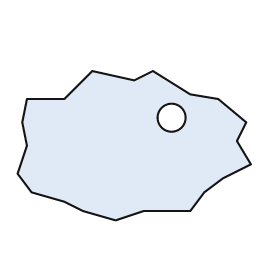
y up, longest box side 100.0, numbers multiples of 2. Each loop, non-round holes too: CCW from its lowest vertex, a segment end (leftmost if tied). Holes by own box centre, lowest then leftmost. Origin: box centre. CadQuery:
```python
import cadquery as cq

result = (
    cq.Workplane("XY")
    .moveTo(-8.0, -32.0)
    .lineTo(4.0, -28.0)
    .lineTo(24.0, -28.0)
    .lineTo(30.0, -20.0)
    .lineTo(38.0, -14.0)
    .lineTo(50.0, -8.0)
    .lineTo(44.0, 2.0)
    .lineTo(48.0, 10.0)
    .lineTo(36.0, 20.0)
    .lineTo(24.0, 22.0)
    .lineTo(8.0, 32.0)
    .lineTo(0.0, 28.0)
    .lineTo(-18.0, 32.0)
    .lineTo(-30.0, 20.0)
    .lineTo(-46.0, 20.0)
    .lineTo(-48.0, 10.0)
    .lineTo(-46.0, 0.0)
    .lineTo(-50.0, -12.0)
    .lineTo(-44.0, -20.0)
    .lineTo(-30.0, -24.0)
    .lineTo(-22.0, -28.0)
    .close()
    .moveTo(16.0, 12.0)
    .circle(6.0)
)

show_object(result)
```